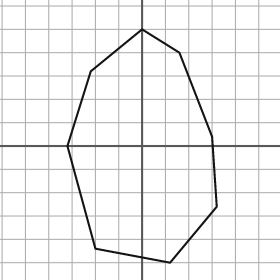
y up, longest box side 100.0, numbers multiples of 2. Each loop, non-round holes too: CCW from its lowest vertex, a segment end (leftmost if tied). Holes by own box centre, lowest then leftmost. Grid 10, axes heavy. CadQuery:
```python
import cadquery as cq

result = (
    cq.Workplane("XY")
    .moveTo(12.0, -50.0)
    .lineTo(32.0, -26.0)
    .lineTo(30.0, 4.0)
    .lineTo(16.0, 40.0)
    .lineTo(0.0, 50.0)
    .lineTo(-22.0, 32.0)
    .lineTo(-32.0, 0.0)
    .lineTo(-20.0, -44.0)
    .close()
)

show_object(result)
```